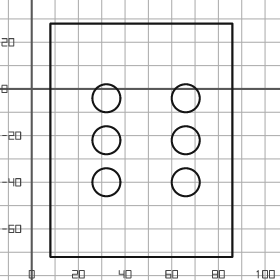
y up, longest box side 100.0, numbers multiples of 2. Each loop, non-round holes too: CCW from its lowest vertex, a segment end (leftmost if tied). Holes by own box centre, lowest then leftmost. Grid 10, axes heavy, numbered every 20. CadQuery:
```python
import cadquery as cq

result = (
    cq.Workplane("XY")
    .moveTo(8.0, -72.0)
    .lineTo(86.0, -72.0)
    .lineTo(86.0, 28.0)
    .lineTo(8.0, 28.0)
    .close()
    .moveTo(32.0, -40.0)
    .circle(6.0)
    .moveTo(66.0, -40.0)
    .circle(6.0)
    .moveTo(32.0, -22.0)
    .circle(6.0)
    .moveTo(66.0, -22.0)
    .circle(6.0)
    .moveTo(32.0, -4.0)
    .circle(6.0)
    .moveTo(66.0, -4.0)
    .circle(6.0)
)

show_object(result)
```